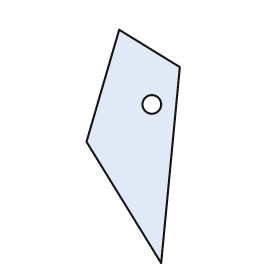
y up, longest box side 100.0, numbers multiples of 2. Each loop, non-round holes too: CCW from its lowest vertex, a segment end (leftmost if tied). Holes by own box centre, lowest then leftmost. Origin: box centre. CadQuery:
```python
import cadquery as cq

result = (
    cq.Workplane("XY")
    .moveTo(12.0, -50.0)
    .lineTo(20.0, 34.0)
    .lineTo(-6.0, 50.0)
    .lineTo(-20.0, 2.0)
    .close()
    .moveTo(8.0, 18.0)
    .circle(4.0)
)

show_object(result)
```